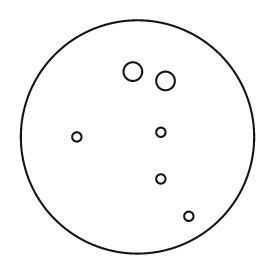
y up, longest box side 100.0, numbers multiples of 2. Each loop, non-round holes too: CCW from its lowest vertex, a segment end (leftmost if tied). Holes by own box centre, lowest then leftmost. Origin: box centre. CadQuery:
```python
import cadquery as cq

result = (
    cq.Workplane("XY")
    .moveTo(0.0, 0.0)
    .circle(50.0)
    .moveTo(22.0, -34.0)
    .circle(2.0)
    .moveTo(10.0, -18.0)
    .circle(2.0)
    .moveTo(-26.0, 0.0)
    .circle(2.0)
    .moveTo(10.0, 2.0)
    .circle(2.0)
    .moveTo(12.0, 24.0)
    .circle(4.0)
    .moveTo(-2.0, 28.0)
    .circle(4.0)
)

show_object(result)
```